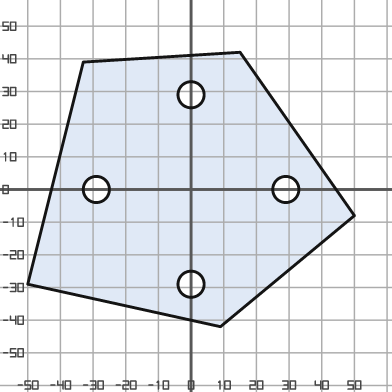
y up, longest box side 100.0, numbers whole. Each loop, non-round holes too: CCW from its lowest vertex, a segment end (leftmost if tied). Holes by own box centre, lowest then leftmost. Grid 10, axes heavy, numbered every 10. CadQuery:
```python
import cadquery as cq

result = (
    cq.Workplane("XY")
    .moveTo(9.0, -42.0)
    .lineTo(50.0, -8.0)
    .lineTo(15.0, 42.0)
    .lineTo(-33.0, 39.0)
    .lineTo(-50.0, -29.0)
    .close()
    .moveTo(0.0, -29.0)
    .circle(4.0)
    .moveTo(-29.0, 0.0)
    .circle(4.0)
    .moveTo(29.0, 0.0)
    .circle(4.0)
    .moveTo(0.0, 29.0)
    .circle(4.0)
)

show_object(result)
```